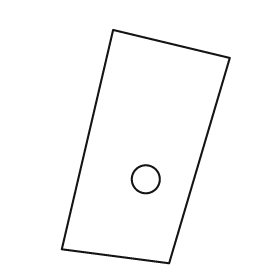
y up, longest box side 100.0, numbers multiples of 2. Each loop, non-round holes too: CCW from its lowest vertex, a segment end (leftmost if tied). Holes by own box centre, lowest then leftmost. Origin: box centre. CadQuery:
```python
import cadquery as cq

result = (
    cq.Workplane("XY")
    .moveTo(10.0, -50.0)
    .lineTo(36.0, 38.0)
    .lineTo(-14.0, 50.0)
    .lineTo(-36.0, -44.0)
    .close()
    .moveTo(0.0, -14.0)
    .circle(6.0)
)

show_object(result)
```